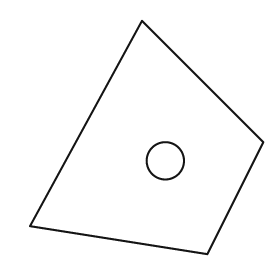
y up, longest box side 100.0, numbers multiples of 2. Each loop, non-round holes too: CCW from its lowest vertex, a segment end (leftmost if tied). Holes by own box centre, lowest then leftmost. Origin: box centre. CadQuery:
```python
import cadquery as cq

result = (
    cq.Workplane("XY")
    .moveTo(26.0, -50.0)
    .lineTo(50.0, -2.0)
    .lineTo(-2.0, 50.0)
    .lineTo(-50.0, -38.0)
    .close()
    .moveTo(8.0, -10.0)
    .circle(8.0)
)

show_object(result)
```